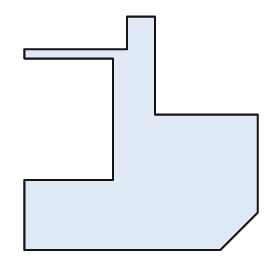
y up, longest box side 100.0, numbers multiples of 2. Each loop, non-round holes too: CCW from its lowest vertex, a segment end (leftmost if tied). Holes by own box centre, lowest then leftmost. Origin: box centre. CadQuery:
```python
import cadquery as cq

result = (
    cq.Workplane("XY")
    .moveTo(-50.0, -50.0)
    .lineTo(34.0, -50.0)
    .lineTo(50.0, -34.0)
    .lineTo(50.0, 8.0)
    .lineTo(6.0, 8.0)
    .lineTo(6.0, 50.0)
    .lineTo(-6.0, 50.0)
    .lineTo(-6.0, 36.0)
    .lineTo(-50.0, 36.0)
    .lineTo(-50.0, 32.0)
    .lineTo(-12.0, 32.0)
    .lineTo(-12.0, -20.0)
    .lineTo(-50.0, -20.0)
    .close()
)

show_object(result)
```